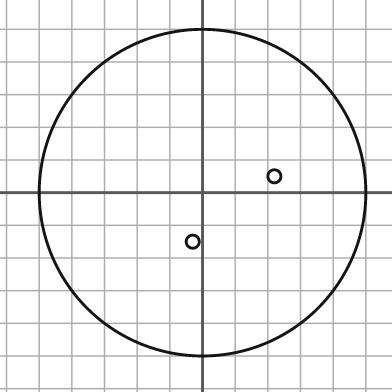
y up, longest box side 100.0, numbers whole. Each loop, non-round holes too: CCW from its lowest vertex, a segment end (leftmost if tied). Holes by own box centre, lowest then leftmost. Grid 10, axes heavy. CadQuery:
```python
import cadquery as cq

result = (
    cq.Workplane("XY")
    .moveTo(0.0, 0.0)
    .circle(50.0)
    .moveTo(-3.0, -15.0)
    .circle(2.0)
    .moveTo(22.0, 5.0)
    .circle(2.0)
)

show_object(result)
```